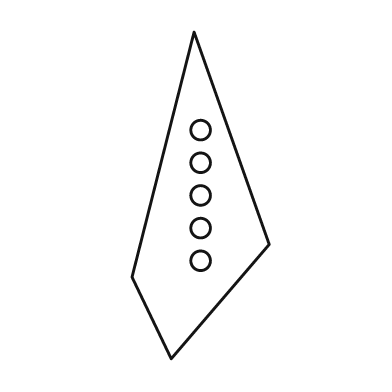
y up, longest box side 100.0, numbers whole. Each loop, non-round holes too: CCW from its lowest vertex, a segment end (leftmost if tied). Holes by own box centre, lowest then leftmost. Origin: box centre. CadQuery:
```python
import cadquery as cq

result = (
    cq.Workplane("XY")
    .moveTo(-9.0, -50.0)
    .lineTo(21.0, -15.0)
    .lineTo(-2.0, 50.0)
    .lineTo(-21.0, -25.0)
    .close()
    .moveTo(0.0, -20.0)
    .circle(3.0)
    .moveTo(0.0, -10.0)
    .circle(3.0)
    .moveTo(0.0, 0.0)
    .circle(3.0)
    .moveTo(0.0, 10.0)
    .circle(3.0)
    .moveTo(0.0, 20.0)
    .circle(3.0)
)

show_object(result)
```